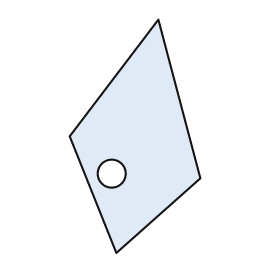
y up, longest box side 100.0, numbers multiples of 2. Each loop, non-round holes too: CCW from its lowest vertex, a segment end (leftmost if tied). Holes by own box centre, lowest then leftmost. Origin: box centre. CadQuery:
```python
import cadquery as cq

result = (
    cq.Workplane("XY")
    .moveTo(-8.0, -50.0)
    .lineTo(28.0, -18.0)
    .lineTo(10.0, 50.0)
    .lineTo(-28.0, 0.0)
    .close()
    .moveTo(-10.0, -16.0)
    .circle(6.0)
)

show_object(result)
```